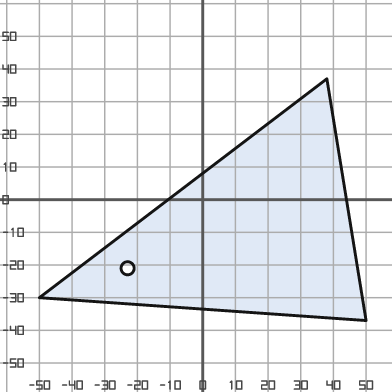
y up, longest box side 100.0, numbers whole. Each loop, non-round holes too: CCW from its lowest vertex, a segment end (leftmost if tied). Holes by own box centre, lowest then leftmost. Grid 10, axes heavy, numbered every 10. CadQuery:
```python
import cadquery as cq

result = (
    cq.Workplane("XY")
    .moveTo(50.0, -37.0)
    .lineTo(38.0, 37.0)
    .lineTo(-50.0, -30.0)
    .close()
    .moveTo(-23.0, -21.0)
    .circle(2.0)
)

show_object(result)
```